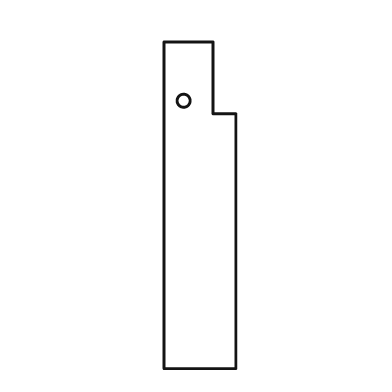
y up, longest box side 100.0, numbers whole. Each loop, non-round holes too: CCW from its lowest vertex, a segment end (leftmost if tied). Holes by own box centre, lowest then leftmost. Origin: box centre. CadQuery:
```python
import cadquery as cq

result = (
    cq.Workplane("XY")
    .moveTo(-11.0, -50.0)
    .lineTo(11.0, -50.0)
    .lineTo(11.0, 28.0)
    .lineTo(4.0, 28.0)
    .lineTo(4.0, 50.0)
    .lineTo(-11.0, 50.0)
    .close()
    .moveTo(-5.0, 32.0)
    .circle(2.0)
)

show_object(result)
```